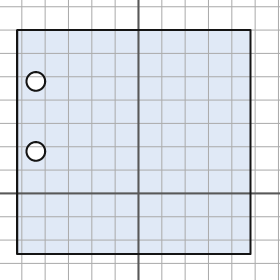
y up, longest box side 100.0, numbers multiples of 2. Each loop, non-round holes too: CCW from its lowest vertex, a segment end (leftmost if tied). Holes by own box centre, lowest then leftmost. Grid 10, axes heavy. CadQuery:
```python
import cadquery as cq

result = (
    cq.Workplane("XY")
    .moveTo(-52.0, -26.0)
    .lineTo(48.0, -26.0)
    .lineTo(48.0, 70.0)
    .lineTo(-52.0, 70.0)
    .close()
    .moveTo(-44.0, 18.0)
    .circle(4.0)
    .moveTo(-44.0, 48.0)
    .circle(4.0)
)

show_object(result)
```